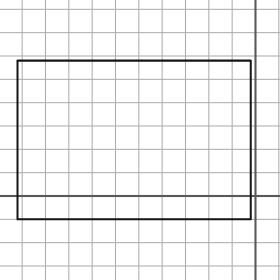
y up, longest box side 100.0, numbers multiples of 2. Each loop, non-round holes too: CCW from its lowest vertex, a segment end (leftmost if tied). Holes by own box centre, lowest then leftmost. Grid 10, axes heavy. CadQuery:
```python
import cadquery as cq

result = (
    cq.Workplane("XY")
    .moveTo(-102.0, -10.0)
    .lineTo(-2.0, -10.0)
    .lineTo(-2.0, 58.0)
    .lineTo(-102.0, 58.0)
    .close()
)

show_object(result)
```